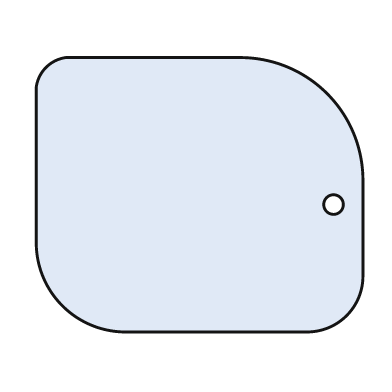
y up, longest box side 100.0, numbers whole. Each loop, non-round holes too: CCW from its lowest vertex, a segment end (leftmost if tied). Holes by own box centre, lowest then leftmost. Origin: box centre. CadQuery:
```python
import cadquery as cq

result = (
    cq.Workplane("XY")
    .moveTo(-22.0, -42.0)
    .lineTo(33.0, -42.0)
    .threePointArc((45.0, -37.0), (50.0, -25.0))
    .lineTo(50.0, 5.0)
    .threePointArc((39.0, 31.0), (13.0, 42.0))
    .lineTo(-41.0, 42.0)
    .threePointArc((-47.0, 39.0), (-50.0, 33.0))
    .lineTo(-50.0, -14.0)
    .threePointArc((-42.0, -34.0), (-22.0, -42.0))
    .close()
    .moveTo(41.0, -3.0)
    .circle(3.0)
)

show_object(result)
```